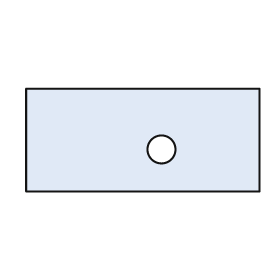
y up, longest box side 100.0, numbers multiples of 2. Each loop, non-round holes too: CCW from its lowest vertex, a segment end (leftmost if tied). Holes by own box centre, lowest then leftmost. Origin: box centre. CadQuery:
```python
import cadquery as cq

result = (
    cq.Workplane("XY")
    .moveTo(-50.0, -22.0)
    .lineTo(50.0, -22.0)
    .lineTo(50.0, 22.0)
    .lineTo(-50.0, 22.0)
    .close()
    .moveTo(8.0, -4.0)
    .circle(6.0)
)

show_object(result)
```